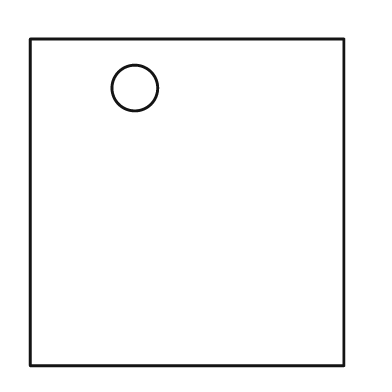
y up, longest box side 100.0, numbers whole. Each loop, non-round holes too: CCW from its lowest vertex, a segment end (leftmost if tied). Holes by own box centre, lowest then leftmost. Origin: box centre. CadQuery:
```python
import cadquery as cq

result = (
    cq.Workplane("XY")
    .moveTo(-48.0, -50.0)
    .lineTo(48.0, -50.0)
    .lineTo(48.0, 50.0)
    .lineTo(-48.0, 50.0)
    .close()
    .moveTo(-16.0, 35.0)
    .circle(7.0)
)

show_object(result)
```